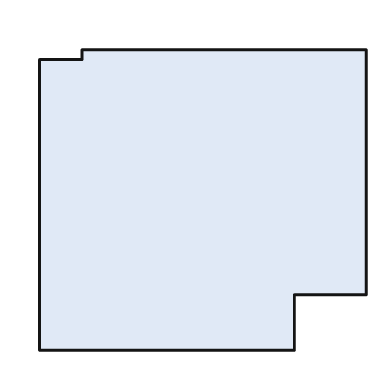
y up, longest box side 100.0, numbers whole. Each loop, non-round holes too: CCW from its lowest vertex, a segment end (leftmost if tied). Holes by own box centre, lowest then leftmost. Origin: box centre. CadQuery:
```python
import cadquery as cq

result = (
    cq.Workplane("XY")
    .moveTo(-50.0, -46.0)
    .lineTo(28.0, -46.0)
    .lineTo(28.0, -29.0)
    .lineTo(50.0, -29.0)
    .lineTo(50.0, 46.0)
    .lineTo(-37.0, 46.0)
    .lineTo(-37.0, 43.0)
    .lineTo(-50.0, 43.0)
    .close()
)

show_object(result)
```